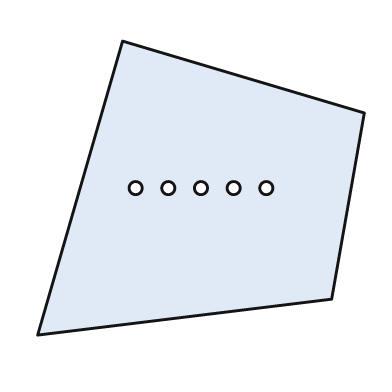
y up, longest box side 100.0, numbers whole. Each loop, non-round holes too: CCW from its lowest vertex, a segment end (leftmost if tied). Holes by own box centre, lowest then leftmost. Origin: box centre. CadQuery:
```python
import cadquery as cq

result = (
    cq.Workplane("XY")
    .moveTo(-50.0, -45.0)
    .lineTo(40.0, -34.0)
    .lineTo(50.0, 23.0)
    .lineTo(-24.0, 45.0)
    .close()
    .moveTo(-20.0, 0.0)
    .circle(2.0)
    .moveTo(-10.0, 0.0)
    .circle(2.0)
    .moveTo(0.0, 0.0)
    .circle(2.0)
    .moveTo(10.0, 0.0)
    .circle(2.0)
    .moveTo(20.0, 0.0)
    .circle(2.0)
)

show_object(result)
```